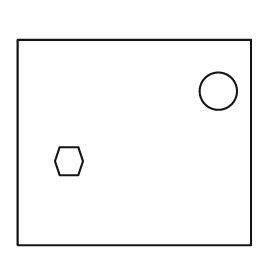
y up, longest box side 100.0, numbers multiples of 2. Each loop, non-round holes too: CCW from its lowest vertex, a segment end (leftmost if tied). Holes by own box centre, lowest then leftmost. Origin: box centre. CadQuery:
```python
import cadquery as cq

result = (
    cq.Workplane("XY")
    .moveTo(-50.0, -44.0)
    .lineTo(50.0, -44.0)
    .lineTo(50.0, 44.0)
    .lineTo(-50.0, 44.0)
    .close()
    .moveTo(-32.0, -14.0)
    .lineTo(-24.0, -14.0)
    .lineTo(-22.0, -8.0)
    .lineTo(-24.0, -2.0)
    .lineTo(-32.0, -2.0)
    .lineTo(-34.0, -8.0)
    .close()
    .moveTo(36.0, 22.0)
    .circle(8.0)
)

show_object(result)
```